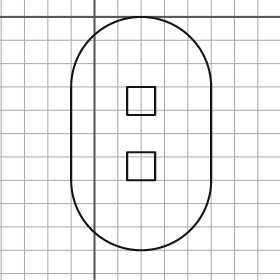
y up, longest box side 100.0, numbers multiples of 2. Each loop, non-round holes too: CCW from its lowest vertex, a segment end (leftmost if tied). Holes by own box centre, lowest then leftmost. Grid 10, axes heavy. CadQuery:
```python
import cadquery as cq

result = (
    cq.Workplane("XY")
    .moveTo(-10.0, -70.0)
    .threePointArc((20.0, -100.0), (50.0, -70.0))
    .lineTo(50.0, -30.0)
    .threePointArc((20.0, 0.0), (-10.0, -30.0))
    .close()
    .moveTo(14.0, -70.0)
    .lineTo(26.0, -70.0)
    .lineTo(26.0, -58.0)
    .lineTo(14.0, -58.0)
    .close()
    .moveTo(14.0, -42.0)
    .lineTo(26.0, -42.0)
    .lineTo(26.0, -30.0)
    .lineTo(14.0, -30.0)
    .close()
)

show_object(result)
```